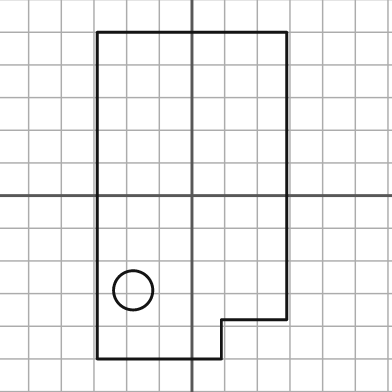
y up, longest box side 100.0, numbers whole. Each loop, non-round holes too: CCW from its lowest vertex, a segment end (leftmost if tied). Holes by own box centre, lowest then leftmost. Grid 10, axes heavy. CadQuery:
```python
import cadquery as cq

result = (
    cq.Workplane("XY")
    .moveTo(-29.0, -50.0)
    .lineTo(9.0, -50.0)
    .lineTo(9.0, -38.0)
    .lineTo(29.0, -38.0)
    .lineTo(29.0, 50.0)
    .lineTo(-29.0, 50.0)
    .close()
    .moveTo(-18.0, -29.0)
    .circle(6.0)
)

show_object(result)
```